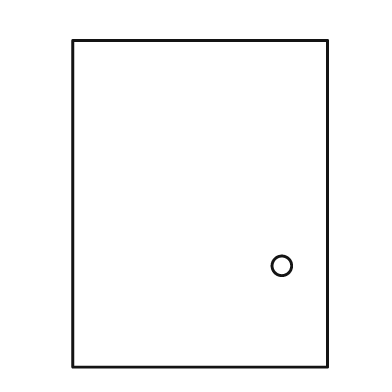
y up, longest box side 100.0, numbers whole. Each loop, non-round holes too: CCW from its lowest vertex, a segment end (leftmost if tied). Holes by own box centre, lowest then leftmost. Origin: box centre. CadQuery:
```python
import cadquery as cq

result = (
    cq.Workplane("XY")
    .moveTo(-39.0, -50.0)
    .lineTo(39.0, -50.0)
    .lineTo(39.0, 50.0)
    .lineTo(-39.0, 50.0)
    .close()
    .moveTo(25.0, -19.0)
    .circle(3.0)
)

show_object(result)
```